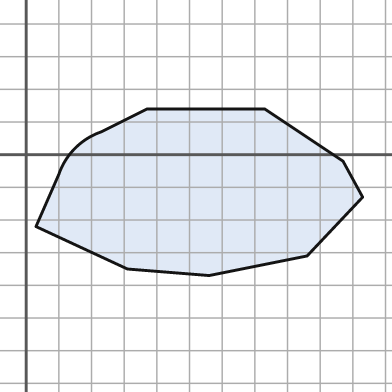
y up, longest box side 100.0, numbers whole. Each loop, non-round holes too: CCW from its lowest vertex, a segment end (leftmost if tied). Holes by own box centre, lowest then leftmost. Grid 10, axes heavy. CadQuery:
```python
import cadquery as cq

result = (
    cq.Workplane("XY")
    .moveTo(56.0, -37.0)
    .lineTo(86.0, -31.0)
    .lineTo(103.0, -13.0)
    .lineTo(97.0, -2.0)
    .lineTo(73.0, 14.0)
    .lineTo(37.0, 14.0)
    .lineTo(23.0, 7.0)
    .threePointArc((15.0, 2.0), (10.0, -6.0))
    .lineTo(3.0, -22.0)
    .lineTo(31.0, -35.0)
    .close()
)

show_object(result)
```